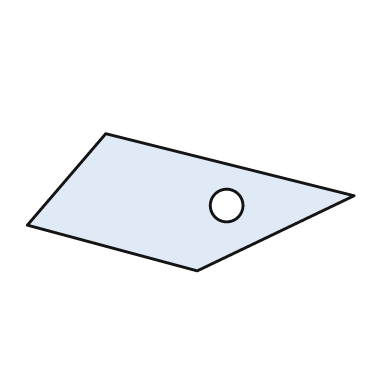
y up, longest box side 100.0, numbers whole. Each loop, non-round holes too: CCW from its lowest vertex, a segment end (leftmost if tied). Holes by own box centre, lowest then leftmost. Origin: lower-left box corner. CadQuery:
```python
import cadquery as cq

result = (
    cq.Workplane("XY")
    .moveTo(52.0, 0.0)
    .lineTo(100.0, 23.0)
    .lineTo(24.0, 42.0)
    .lineTo(0.0, 14.0)
    .close()
    .moveTo(61.0, 20.0)
    .circle(5.0)
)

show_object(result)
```